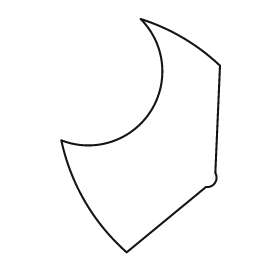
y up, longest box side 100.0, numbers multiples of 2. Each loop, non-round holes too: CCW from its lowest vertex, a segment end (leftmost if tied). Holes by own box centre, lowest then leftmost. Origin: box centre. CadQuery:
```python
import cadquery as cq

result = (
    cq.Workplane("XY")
    .moveTo(-6.0, -50.0)
    .lineTo(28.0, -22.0)
    .threePointArc((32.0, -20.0), (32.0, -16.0))
    .lineTo(34.0, 30.0)
    .threePointArc((18.0, 42.0), (0.0, 50.0))
    .threePointArc((4.0, 10.0), (-34.0, -2.0))
    .threePointArc((-24.0, -28.0), (-6.0, -50.0))
    .close()
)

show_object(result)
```